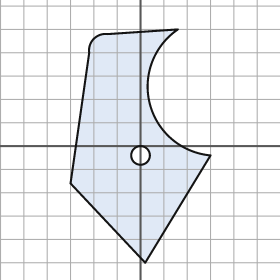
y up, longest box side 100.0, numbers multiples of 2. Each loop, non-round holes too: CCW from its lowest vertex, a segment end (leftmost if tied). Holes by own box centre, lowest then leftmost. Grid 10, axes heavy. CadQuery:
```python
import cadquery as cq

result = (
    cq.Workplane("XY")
    .moveTo(2.0, -50.0)
    .lineTo(30.0, -4.0)
    .threePointArc((4.0, 18.0), (16.0, 50.0))
    .lineTo(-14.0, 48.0)
    .threePointArc((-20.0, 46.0), (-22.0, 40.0))
    .lineTo(-30.0, -16.0)
    .close()
    .moveTo(0.0, -4.0)
    .circle(4.0)
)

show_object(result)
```